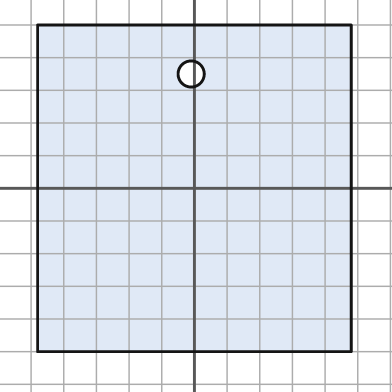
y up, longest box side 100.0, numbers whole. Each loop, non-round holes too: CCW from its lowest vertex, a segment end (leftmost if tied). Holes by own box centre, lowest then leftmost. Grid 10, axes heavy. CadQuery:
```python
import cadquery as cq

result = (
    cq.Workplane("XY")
    .moveTo(-48.0, -50.0)
    .lineTo(48.0, -50.0)
    .lineTo(48.0, 50.0)
    .lineTo(-48.0, 50.0)
    .close()
    .moveTo(-1.0, 35.0)
    .circle(4.0)
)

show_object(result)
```